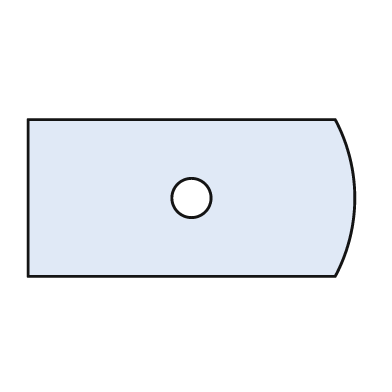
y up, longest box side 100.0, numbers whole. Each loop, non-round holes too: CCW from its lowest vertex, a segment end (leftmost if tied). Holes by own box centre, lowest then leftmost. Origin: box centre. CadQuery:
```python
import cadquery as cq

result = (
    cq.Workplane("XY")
    .moveTo(-50.0, -24.0)
    .lineTo(44.0, -24.0)
    .threePointArc((50.0, 0.0), (44.0, 24.0))
    .lineTo(-50.0, 24.0)
    .close()
    .moveTo(0.0, 0.0)
    .circle(6.0)
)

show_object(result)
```